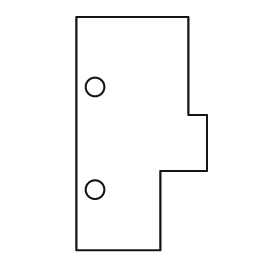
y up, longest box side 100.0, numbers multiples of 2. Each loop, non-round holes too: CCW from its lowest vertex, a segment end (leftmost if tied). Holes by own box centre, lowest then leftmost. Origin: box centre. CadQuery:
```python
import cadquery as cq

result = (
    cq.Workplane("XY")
    .moveTo(-28.0, -50.0)
    .lineTo(8.0, -50.0)
    .lineTo(8.0, -16.0)
    .lineTo(28.0, -16.0)
    .lineTo(28.0, 8.0)
    .lineTo(20.0, 8.0)
    .lineTo(20.0, 50.0)
    .lineTo(-28.0, 50.0)
    .close()
    .moveTo(-20.0, -24.0)
    .circle(4.0)
    .moveTo(-20.0, 20.0)
    .circle(4.0)
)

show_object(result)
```